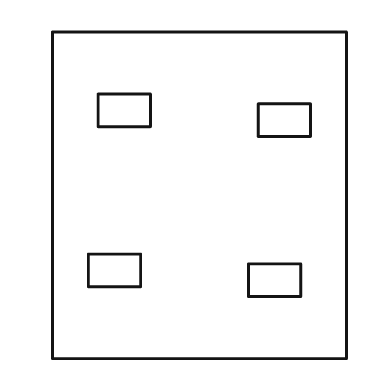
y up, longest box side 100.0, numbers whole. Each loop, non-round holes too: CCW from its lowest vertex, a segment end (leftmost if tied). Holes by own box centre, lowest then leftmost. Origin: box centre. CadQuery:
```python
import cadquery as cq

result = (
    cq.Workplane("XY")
    .moveTo(-45.0, -50.0)
    .lineTo(45.0, -50.0)
    .lineTo(45.0, 50.0)
    .lineTo(-45.0, 50.0)
    .close()
    .moveTo(15.0, -31.0)
    .lineTo(31.0, -31.0)
    .lineTo(31.0, -21.0)
    .lineTo(15.0, -21.0)
    .close()
    .moveTo(-34.0, -28.0)
    .lineTo(-18.0, -28.0)
    .lineTo(-18.0, -18.0)
    .lineTo(-34.0, -18.0)
    .close()
    .moveTo(18.0, 18.0)
    .lineTo(34.0, 18.0)
    .lineTo(34.0, 28.0)
    .lineTo(18.0, 28.0)
    .close()
    .moveTo(-31.0, 21.0)
    .lineTo(-15.0, 21.0)
    .lineTo(-15.0, 31.0)
    .lineTo(-31.0, 31.0)
    .close()
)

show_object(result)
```